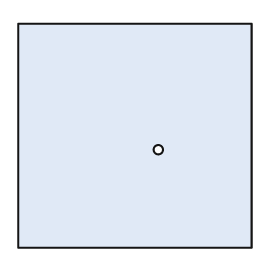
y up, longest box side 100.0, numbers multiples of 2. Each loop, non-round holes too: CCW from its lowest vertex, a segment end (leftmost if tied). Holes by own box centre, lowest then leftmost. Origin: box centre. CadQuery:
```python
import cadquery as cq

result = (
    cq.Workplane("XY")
    .moveTo(-50.0, -48.0)
    .lineTo(50.0, -48.0)
    .lineTo(50.0, 48.0)
    .lineTo(-50.0, 48.0)
    .close()
    .moveTo(10.0, -6.0)
    .circle(2.0)
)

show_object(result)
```